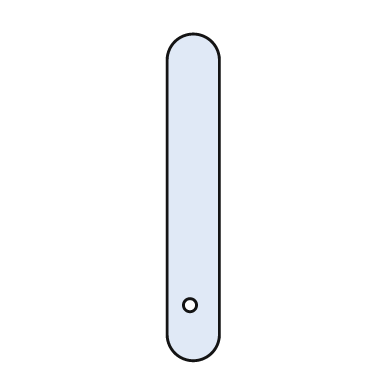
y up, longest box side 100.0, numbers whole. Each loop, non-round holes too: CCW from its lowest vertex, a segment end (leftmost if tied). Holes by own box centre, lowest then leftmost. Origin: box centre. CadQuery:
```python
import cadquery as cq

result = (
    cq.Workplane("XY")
    .moveTo(-8.0, -42.0)
    .threePointArc((0.0, -50.0), (8.0, -42.0))
    .lineTo(8.0, 42.0)
    .threePointArc((0.0, 50.0), (-8.0, 42.0))
    .close()
    .moveTo(-1.0, -33.0)
    .circle(2.0)
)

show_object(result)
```